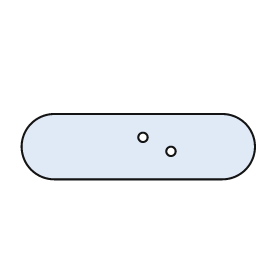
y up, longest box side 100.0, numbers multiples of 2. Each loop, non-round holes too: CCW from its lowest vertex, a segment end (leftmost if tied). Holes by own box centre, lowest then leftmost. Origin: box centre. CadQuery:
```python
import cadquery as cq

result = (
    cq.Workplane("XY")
    .moveTo(-36.0, -14.0)
    .lineTo(36.0, -14.0)
    .threePointArc((50.0, 0.0), (36.0, 14.0))
    .lineTo(-36.0, 14.0)
    .threePointArc((-50.0, 0.0), (-36.0, -14.0))
    .close()
    .moveTo(14.0, -2.0)
    .circle(2.0)
    .moveTo(2.0, 4.0)
    .circle(2.0)
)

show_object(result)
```